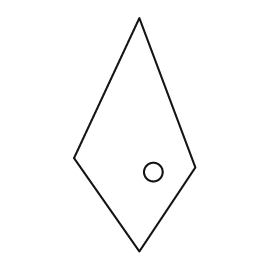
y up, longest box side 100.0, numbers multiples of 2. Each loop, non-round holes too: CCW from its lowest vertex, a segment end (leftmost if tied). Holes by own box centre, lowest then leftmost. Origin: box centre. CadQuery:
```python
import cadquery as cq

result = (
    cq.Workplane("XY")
    .moveTo(2.0, -50.0)
    .lineTo(26.0, -14.0)
    .lineTo(2.0, 50.0)
    .lineTo(-26.0, -10.0)
    .close()
    .moveTo(8.0, -16.0)
    .circle(4.0)
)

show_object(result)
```